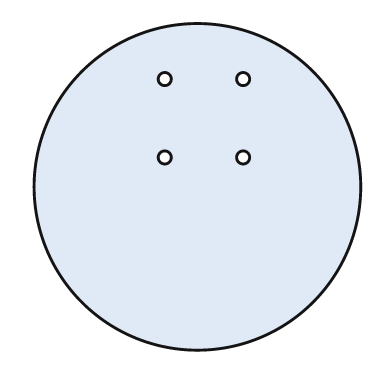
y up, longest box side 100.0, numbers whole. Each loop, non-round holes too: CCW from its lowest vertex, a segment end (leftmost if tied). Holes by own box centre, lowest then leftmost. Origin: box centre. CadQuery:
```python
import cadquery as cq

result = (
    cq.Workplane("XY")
    .moveTo(0.0, 0.0)
    .circle(50.0)
    .moveTo(-10.0, 9.0)
    .circle(2.0)
    .moveTo(14.0, 9.0)
    .circle(2.0)
    .moveTo(-10.0, 33.0)
    .circle(2.0)
    .moveTo(14.0, 33.0)
    .circle(2.0)
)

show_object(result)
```